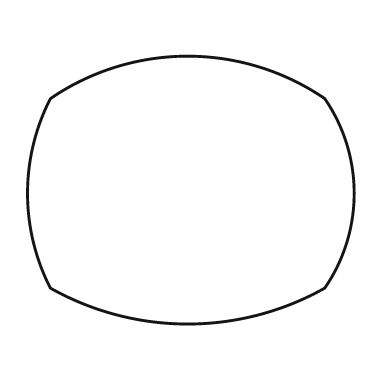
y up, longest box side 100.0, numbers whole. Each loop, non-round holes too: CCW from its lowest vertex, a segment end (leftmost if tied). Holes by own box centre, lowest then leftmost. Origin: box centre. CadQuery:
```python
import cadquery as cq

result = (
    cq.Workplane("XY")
    .moveTo(-43.0, -30.0)
    .threePointArc((-1.0, -41.0), (41.0, -30.0))
    .threePointArc((50.0, -1.0), (41.0, 28.0))
    .threePointArc((-1.0, 41.0), (-43.0, 28.0))
    .threePointArc((-50.0, -1.0), (-43.0, -30.0))
    .close()
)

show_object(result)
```